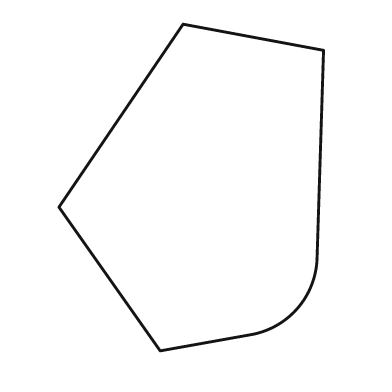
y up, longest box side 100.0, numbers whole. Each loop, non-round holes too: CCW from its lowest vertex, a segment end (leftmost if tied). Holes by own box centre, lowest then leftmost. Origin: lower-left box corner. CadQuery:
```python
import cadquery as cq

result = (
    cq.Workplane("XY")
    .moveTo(31.0, 0.0)
    .lineTo(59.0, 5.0)
    .threePointArc((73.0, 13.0), (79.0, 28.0))
    .lineTo(81.0, 92.0)
    .lineTo(38.0, 100.0)
    .lineTo(0.0, 44.0)
    .close()
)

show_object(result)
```